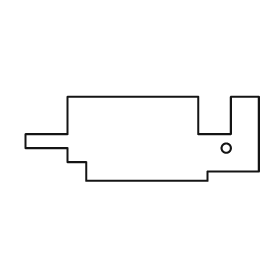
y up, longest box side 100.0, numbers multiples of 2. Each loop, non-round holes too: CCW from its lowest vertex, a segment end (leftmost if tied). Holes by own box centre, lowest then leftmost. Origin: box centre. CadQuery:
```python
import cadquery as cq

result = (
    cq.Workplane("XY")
    .moveTo(-24.0, -18.0)
    .lineTo(28.0, -18.0)
    .lineTo(28.0, -14.0)
    .lineTo(50.0, -14.0)
    .lineTo(50.0, 18.0)
    .lineTo(38.0, 18.0)
    .lineTo(38.0, 2.0)
    .lineTo(24.0, 2.0)
    .lineTo(24.0, 18.0)
    .lineTo(-32.0, 18.0)
    .lineTo(-32.0, 2.0)
    .lineTo(-50.0, 2.0)
    .lineTo(-50.0, -4.0)
    .lineTo(-32.0, -4.0)
    .lineTo(-32.0, -10.0)
    .lineTo(-24.0, -10.0)
    .close()
    .moveTo(36.0, -4.0)
    .circle(2.0)
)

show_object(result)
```